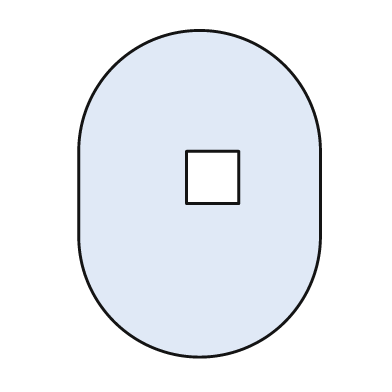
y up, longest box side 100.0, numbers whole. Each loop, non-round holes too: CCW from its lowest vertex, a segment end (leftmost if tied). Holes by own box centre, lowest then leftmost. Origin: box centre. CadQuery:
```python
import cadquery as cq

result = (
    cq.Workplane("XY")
    .moveTo(-37.0, -13.0)
    .threePointArc((0.0, -50.0), (37.0, -13.0))
    .lineTo(37.0, 13.0)
    .threePointArc((0.0, 50.0), (-37.0, 13.0))
    .close()
    .moveTo(-4.0, -3.0)
    .lineTo(12.0, -3.0)
    .lineTo(12.0, 13.0)
    .lineTo(-4.0, 13.0)
    .close()
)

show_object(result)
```